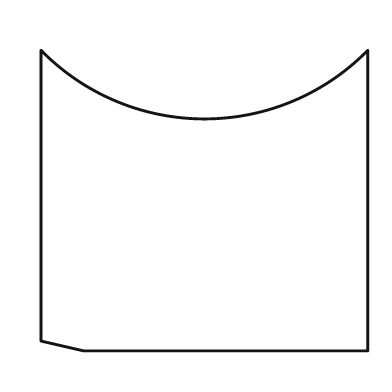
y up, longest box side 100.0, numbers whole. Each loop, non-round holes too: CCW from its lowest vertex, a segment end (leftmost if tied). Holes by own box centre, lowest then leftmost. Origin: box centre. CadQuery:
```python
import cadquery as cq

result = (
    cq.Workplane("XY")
    .moveTo(-37.0, -46.0)
    .lineTo(50.0, -46.0)
    .lineTo(50.0, 46.0)
    .threePointArc((0.0, 25.0), (-50.0, 46.0))
    .lineTo(-50.0, -43.0)
    .close()
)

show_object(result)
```